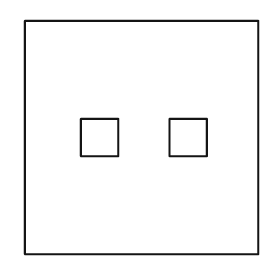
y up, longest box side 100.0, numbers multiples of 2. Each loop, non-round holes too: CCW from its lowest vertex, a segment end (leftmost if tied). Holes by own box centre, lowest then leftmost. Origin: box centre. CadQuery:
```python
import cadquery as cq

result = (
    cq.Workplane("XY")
    .moveTo(-50.0, -50.0)
    .lineTo(50.0, -50.0)
    .lineTo(50.0, 50.0)
    .lineTo(-50.0, 50.0)
    .close()
    .moveTo(-26.0, -8.0)
    .lineTo(-10.0, -8.0)
    .lineTo(-10.0, 8.0)
    .lineTo(-26.0, 8.0)
    .close()
    .moveTo(12.0, -8.0)
    .lineTo(28.0, -8.0)
    .lineTo(28.0, 8.0)
    .lineTo(12.0, 8.0)
    .close()
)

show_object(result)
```